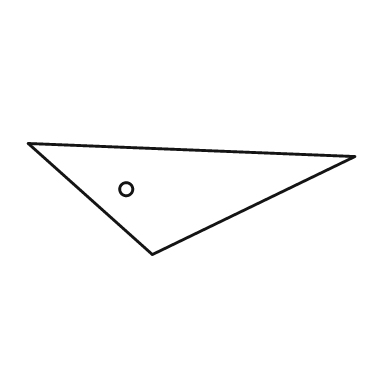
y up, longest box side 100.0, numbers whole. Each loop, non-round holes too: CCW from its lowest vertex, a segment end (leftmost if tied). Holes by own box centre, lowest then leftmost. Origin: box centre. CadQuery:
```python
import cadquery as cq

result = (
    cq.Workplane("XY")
    .moveTo(-12.0, -17.0)
    .lineTo(50.0, 13.0)
    .lineTo(-50.0, 17.0)
    .close()
    .moveTo(-20.0, 3.0)
    .circle(2.0)
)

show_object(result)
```